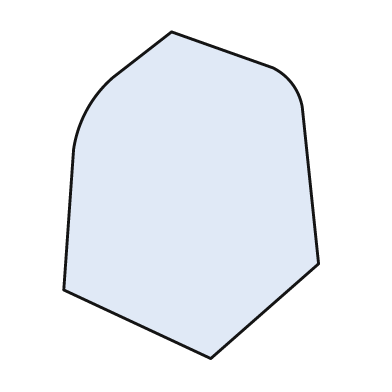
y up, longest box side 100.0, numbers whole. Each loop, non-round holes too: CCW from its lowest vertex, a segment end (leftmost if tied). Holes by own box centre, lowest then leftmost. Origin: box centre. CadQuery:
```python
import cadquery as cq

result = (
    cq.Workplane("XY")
    .moveTo(6.0, -50.0)
    .lineTo(39.0, -21.0)
    .lineTo(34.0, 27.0)
    .threePointArc((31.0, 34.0), (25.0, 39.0))
    .lineTo(-6.0, 50.0)
    .lineTo(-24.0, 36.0)
    .threePointArc((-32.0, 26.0), (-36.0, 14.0))
    .lineTo(-39.0, -29.0)
    .close()
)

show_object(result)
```